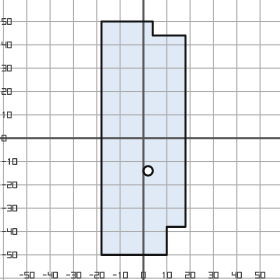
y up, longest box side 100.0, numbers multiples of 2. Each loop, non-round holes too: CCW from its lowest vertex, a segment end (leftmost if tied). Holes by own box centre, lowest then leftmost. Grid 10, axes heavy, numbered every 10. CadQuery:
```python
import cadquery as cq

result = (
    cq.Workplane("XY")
    .moveTo(-18.0, -50.0)
    .lineTo(10.0, -50.0)
    .lineTo(10.0, -38.0)
    .lineTo(18.0, -38.0)
    .lineTo(18.0, 44.0)
    .lineTo(4.0, 44.0)
    .lineTo(4.0, 50.0)
    .lineTo(-18.0, 50.0)
    .close()
    .moveTo(2.0, -14.0)
    .circle(2.0)
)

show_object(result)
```